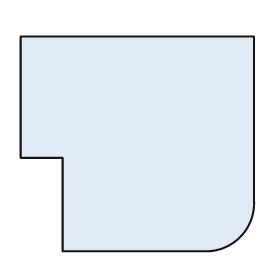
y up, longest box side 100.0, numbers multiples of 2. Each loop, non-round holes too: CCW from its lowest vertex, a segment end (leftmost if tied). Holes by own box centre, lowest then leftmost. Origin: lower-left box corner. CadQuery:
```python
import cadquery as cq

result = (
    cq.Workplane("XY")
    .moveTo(18.0, 0.0)
    .lineTo(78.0, 0.0)
    .threePointArc((94.0, 6.0), (100.0, 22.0))
    .lineTo(100.0, 92.0)
    .lineTo(0.0, 92.0)
    .lineTo(0.0, 40.0)
    .lineTo(18.0, 40.0)
    .close()
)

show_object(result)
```